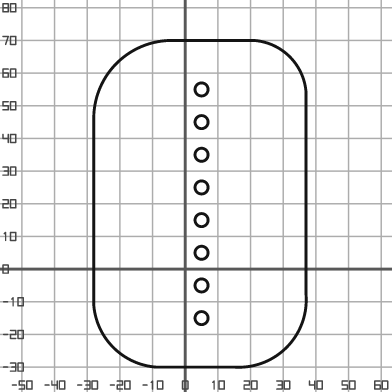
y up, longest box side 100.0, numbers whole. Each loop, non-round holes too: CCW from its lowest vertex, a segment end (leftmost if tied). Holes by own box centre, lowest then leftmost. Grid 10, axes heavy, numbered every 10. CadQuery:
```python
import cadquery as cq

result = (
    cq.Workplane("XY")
    .moveTo(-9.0, -30.0)
    .lineTo(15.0, -30.0)
    .threePointArc((31.0, -24.0), (37.0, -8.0))
    .lineTo(37.0, 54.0)
    .threePointArc((32.0, 65.0), (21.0, 70.0))
    .lineTo(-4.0, 70.0)
    .threePointArc((-21.0, 63.0), (-28.0, 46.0))
    .lineTo(-28.0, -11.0)
    .threePointArc((-22.0, -24.0), (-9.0, -30.0))
    .close()
    .moveTo(5.0, -15.0)
    .circle(2.0)
    .moveTo(5.0, -5.0)
    .circle(2.0)
    .moveTo(5.0, 5.0)
    .circle(2.0)
    .moveTo(5.0, 15.0)
    .circle(2.0)
    .moveTo(5.0, 25.0)
    .circle(2.0)
    .moveTo(5.0, 35.0)
    .circle(2.0)
    .moveTo(5.0, 45.0)
    .circle(2.0)
    .moveTo(5.0, 55.0)
    .circle(2.0)
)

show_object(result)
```